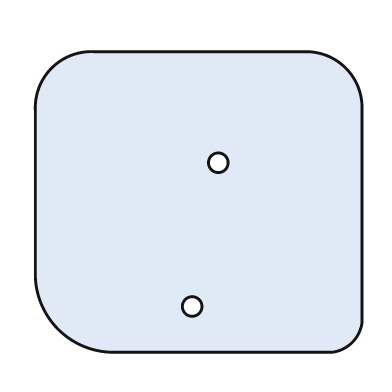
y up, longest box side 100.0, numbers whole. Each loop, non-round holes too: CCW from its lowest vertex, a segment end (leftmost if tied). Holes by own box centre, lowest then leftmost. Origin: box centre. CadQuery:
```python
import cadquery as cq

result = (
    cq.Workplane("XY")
    .moveTo(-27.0, -46.0)
    .lineTo(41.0, -46.0)
    .threePointArc((47.0, -43.0), (50.0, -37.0))
    .lineTo(50.0, 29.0)
    .threePointArc((45.0, 41.0), (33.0, 46.0))
    .lineTo(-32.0, 46.0)
    .threePointArc((-45.0, 41.0), (-50.0, 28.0))
    .lineTo(-50.0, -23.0)
    .threePointArc((-43.0, -39.0), (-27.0, -46.0))
    .close()
    .moveTo(-2.0, -32.0)
    .circle(3.0)
    .moveTo(6.0, 12.0)
    .circle(3.0)
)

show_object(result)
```